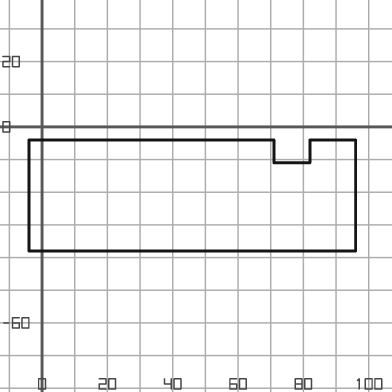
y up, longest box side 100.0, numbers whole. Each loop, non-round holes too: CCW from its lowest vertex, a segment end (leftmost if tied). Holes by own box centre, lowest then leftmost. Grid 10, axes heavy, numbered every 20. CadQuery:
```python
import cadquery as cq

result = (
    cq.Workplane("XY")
    .moveTo(-4.0, -38.0)
    .lineTo(96.0, -38.0)
    .lineTo(96.0, -4.0)
    .lineTo(82.0, -4.0)
    .lineTo(82.0, -11.0)
    .lineTo(71.0, -11.0)
    .lineTo(71.0, -4.0)
    .lineTo(-4.0, -4.0)
    .close()
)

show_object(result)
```